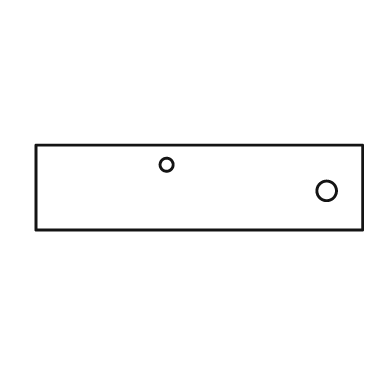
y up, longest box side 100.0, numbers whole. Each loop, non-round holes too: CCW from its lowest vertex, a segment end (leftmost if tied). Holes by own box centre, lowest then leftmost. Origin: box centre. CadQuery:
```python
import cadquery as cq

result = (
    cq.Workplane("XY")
    .moveTo(-50.0, -13.0)
    .lineTo(50.0, -13.0)
    .lineTo(50.0, 13.0)
    .lineTo(-50.0, 13.0)
    .close()
    .moveTo(39.0, -1.0)
    .circle(3.0)
    .moveTo(-10.0, 7.0)
    .circle(2.0)
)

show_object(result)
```